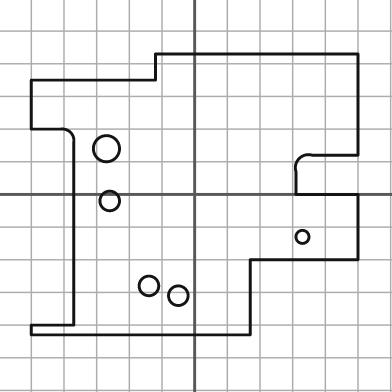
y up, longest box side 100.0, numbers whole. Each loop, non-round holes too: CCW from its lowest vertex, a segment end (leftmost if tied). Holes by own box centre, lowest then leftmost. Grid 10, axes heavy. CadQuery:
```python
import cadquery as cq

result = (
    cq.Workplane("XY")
    .moveTo(-50.0, -43.0)
    .lineTo(17.0, -43.0)
    .lineTo(17.0, -20.0)
    .lineTo(50.0, -20.0)
    .lineTo(50.0, 0.0)
    .lineTo(31.0, 0.0)
    .lineTo(31.0, 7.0)
    .threePointArc((32.0, 11.0), (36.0, 12.0))
    .lineTo(50.0, 12.0)
    .lineTo(50.0, 43.0)
    .lineTo(-12.0, 43.0)
    .lineTo(-12.0, 35.0)
    .lineTo(-50.0, 35.0)
    .lineTo(-50.0, 20.0)
    .lineTo(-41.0, 20.0)
    .threePointArc((-38.0, 19.0), (-37.0, 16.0))
    .lineTo(-37.0, -40.0)
    .lineTo(-50.0, -40.0)
    .close()
    .moveTo(-5.0, -31.0)
    .circle(3.0)
    .moveTo(-14.0, -28.0)
    .circle(3.0)
    .moveTo(33.0, -13.0)
    .circle(2.0)
    .moveTo(-26.0, -2.0)
    .circle(3.0)
    .moveTo(-27.0, 14.0)
    .circle(4.0)
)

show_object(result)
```